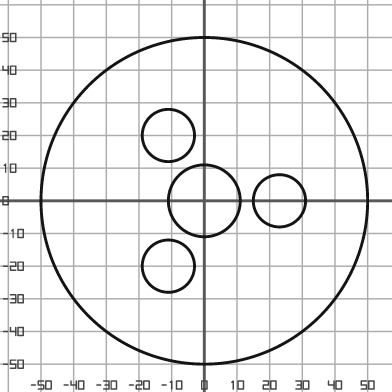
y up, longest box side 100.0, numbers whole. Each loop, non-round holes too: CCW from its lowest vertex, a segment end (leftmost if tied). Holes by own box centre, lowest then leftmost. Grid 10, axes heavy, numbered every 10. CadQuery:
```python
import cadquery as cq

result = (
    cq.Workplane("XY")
    .moveTo(0.0, 0.0)
    .circle(50.0)
    .moveTo(-11.0, -20.0)
    .circle(8.0)
    .moveTo(0.0, 0.0)
    .circle(11.0)
    .moveTo(23.0, 0.0)
    .circle(8.0)
    .moveTo(-11.0, 20.0)
    .circle(8.0)
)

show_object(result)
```